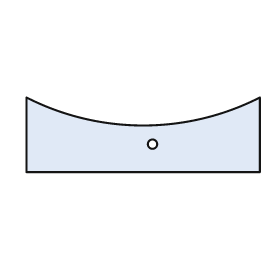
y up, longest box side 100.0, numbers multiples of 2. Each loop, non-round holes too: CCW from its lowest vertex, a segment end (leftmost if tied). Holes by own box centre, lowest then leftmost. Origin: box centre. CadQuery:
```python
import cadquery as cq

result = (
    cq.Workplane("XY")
    .moveTo(-50.0, -16.0)
    .lineTo(50.0, -16.0)
    .lineTo(50.0, 16.0)
    .threePointArc((0.0, 4.0), (-50.0, 16.0))
    .close()
    .moveTo(4.0, -4.0)
    .circle(2.0)
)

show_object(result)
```